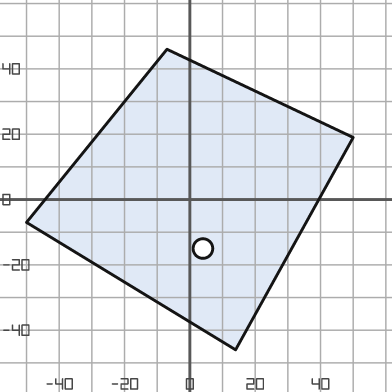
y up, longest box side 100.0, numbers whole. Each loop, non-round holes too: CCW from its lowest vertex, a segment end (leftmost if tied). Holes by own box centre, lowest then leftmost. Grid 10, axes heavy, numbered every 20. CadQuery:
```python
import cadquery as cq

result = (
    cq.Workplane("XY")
    .moveTo(14.0, -46.0)
    .lineTo(50.0, 19.0)
    .lineTo(-7.0, 46.0)
    .lineTo(-50.0, -7.0)
    .close()
    .moveTo(4.0, -15.0)
    .circle(3.0)
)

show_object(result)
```